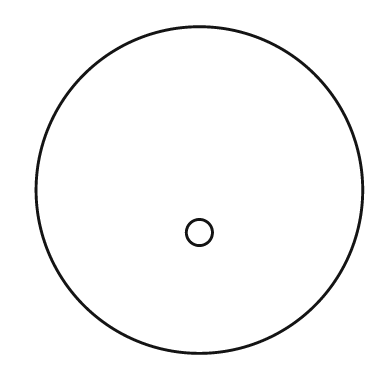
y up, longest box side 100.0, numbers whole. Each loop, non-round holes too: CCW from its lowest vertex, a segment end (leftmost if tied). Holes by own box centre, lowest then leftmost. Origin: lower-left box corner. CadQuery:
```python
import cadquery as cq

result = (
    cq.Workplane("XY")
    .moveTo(50.0, 50.0)
    .circle(50.0)
    .moveTo(50.0, 37.0)
    .circle(4.0)
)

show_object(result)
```